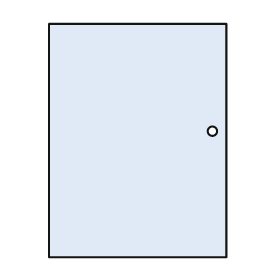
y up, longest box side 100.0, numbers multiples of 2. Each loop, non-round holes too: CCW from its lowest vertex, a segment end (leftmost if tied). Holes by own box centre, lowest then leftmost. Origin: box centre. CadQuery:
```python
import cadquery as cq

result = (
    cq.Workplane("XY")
    .moveTo(-38.0, -50.0)
    .lineTo(38.0, -50.0)
    .lineTo(38.0, 50.0)
    .lineTo(-38.0, 50.0)
    .close()
    .moveTo(32.0, 4.0)
    .circle(2.0)
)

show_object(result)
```